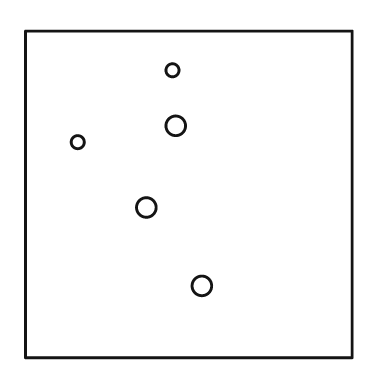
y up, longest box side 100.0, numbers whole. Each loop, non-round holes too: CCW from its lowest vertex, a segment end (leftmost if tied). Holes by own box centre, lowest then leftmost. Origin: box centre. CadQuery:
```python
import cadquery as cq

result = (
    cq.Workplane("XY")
    .moveTo(-50.0, -50.0)
    .lineTo(50.0, -50.0)
    .lineTo(50.0, 50.0)
    .lineTo(-50.0, 50.0)
    .close()
    .moveTo(4.0, -28.0)
    .circle(3.0)
    .moveTo(-13.0, -4.0)
    .circle(3.0)
    .moveTo(-34.0, 16.0)
    .circle(2.0)
    .moveTo(-4.0, 21.0)
    .circle(3.0)
    .moveTo(-5.0, 38.0)
    .circle(2.0)
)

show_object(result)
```